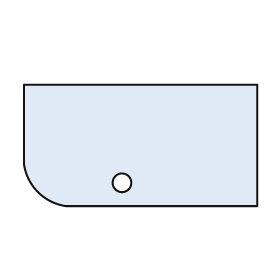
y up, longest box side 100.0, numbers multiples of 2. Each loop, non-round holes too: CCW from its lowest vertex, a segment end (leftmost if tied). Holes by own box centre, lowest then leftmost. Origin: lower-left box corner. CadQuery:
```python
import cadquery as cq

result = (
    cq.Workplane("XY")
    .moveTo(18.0, 0.0)
    .lineTo(100.0, 0.0)
    .lineTo(100.0, 52.0)
    .lineTo(0.0, 52.0)
    .lineTo(0.0, 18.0)
    .threePointArc((6.0, 6.0), (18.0, 0.0))
    .close()
    .moveTo(42.0, 10.0)
    .circle(4.0)
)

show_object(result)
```